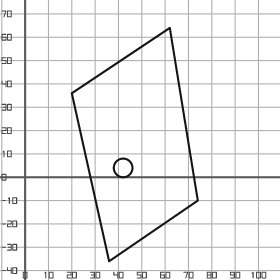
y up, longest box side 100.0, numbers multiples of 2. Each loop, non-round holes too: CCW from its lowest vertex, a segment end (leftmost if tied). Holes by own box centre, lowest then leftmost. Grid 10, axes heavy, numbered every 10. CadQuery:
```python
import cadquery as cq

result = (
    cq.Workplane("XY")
    .moveTo(36.0, -36.0)
    .lineTo(74.0, -10.0)
    .lineTo(62.0, 64.0)
    .lineTo(20.0, 36.0)
    .close()
    .moveTo(42.0, 4.0)
    .circle(4.0)
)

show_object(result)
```